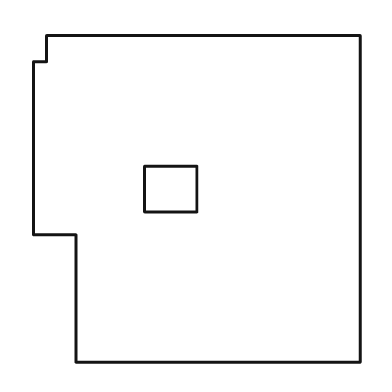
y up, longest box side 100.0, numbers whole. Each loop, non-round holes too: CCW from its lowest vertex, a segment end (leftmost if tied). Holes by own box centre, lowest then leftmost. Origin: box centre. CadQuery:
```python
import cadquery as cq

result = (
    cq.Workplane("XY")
    .moveTo(-37.0, -50.0)
    .lineTo(50.0, -50.0)
    .lineTo(50.0, 50.0)
    .lineTo(-46.0, 50.0)
    .lineTo(-46.0, 42.0)
    .lineTo(-50.0, 42.0)
    .lineTo(-50.0, -11.0)
    .lineTo(-37.0, -11.0)
    .close()
    .moveTo(-16.0, -4.0)
    .lineTo(0.0, -4.0)
    .lineTo(0.0, 10.0)
    .lineTo(-16.0, 10.0)
    .close()
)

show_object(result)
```